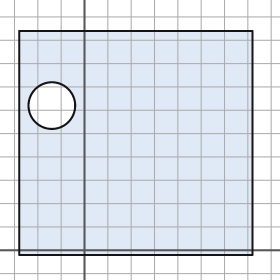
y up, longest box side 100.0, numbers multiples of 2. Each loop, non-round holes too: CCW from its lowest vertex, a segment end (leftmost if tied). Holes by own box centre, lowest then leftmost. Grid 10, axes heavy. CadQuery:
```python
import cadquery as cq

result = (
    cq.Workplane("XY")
    .moveTo(-28.0, -2.0)
    .lineTo(72.0, -2.0)
    .lineTo(72.0, 94.0)
    .lineTo(-28.0, 94.0)
    .close()
    .moveTo(-14.0, 62.0)
    .circle(10.0)
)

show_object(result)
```